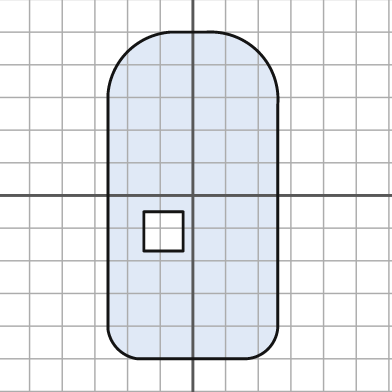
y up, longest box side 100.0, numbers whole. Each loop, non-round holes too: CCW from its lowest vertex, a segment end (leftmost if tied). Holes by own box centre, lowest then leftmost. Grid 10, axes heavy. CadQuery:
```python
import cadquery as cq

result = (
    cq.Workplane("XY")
    .moveTo(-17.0, -50.0)
    .lineTo(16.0, -50.0)
    .threePointArc((23.0, -47.0), (26.0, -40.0))
    .lineTo(26.0, 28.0)
    .threePointArc((20.0, 44.0), (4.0, 50.0))
    .lineTo(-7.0, 50.0)
    .threePointArc((-20.0, 44.0), (-26.0, 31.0))
    .lineTo(-26.0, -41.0)
    .threePointArc((-23.0, -47.0), (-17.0, -50.0))
    .close()
    .moveTo(-15.0, -17.0)
    .lineTo(-3.0, -17.0)
    .lineTo(-3.0, -5.0)
    .lineTo(-15.0, -5.0)
    .close()
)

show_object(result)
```